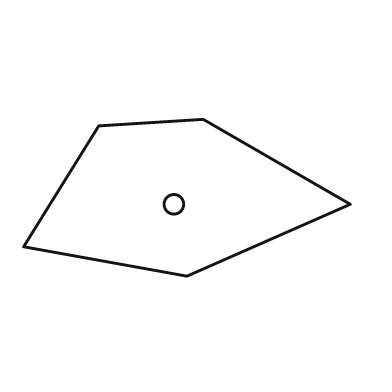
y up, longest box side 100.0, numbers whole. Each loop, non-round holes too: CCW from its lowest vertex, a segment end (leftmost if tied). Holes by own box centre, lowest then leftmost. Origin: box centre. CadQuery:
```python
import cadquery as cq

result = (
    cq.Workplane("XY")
    .moveTo(0.0, -24.0)
    .lineTo(50.0, -2.0)
    .lineTo(5.0, 24.0)
    .lineTo(-27.0, 22.0)
    .lineTo(-50.0, -15.0)
    .close()
    .moveTo(-4.0, -2.0)
    .circle(3.0)
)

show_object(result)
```